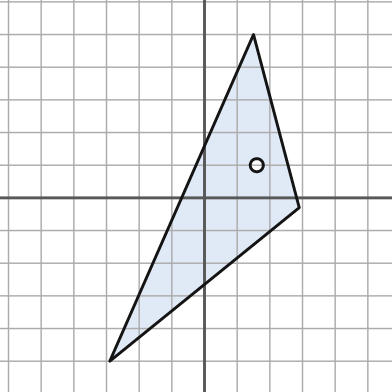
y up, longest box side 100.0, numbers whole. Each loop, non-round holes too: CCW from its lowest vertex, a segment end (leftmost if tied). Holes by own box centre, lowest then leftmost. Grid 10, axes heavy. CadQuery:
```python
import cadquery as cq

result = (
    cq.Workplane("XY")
    .moveTo(-29.0, -50.0)
    .lineTo(29.0, -3.0)
    .lineTo(15.0, 50.0)
    .close()
    .moveTo(16.0, 10.0)
    .circle(2.0)
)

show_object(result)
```